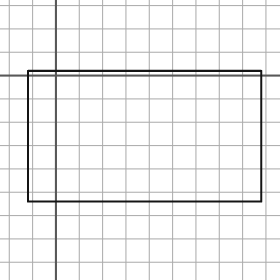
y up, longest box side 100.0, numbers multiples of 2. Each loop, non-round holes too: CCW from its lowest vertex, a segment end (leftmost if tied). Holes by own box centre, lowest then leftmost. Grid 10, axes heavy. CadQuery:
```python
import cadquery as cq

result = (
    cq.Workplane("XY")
    .moveTo(-12.0, -54.0)
    .lineTo(88.0, -54.0)
    .lineTo(88.0, 2.0)
    .lineTo(-12.0, 2.0)
    .close()
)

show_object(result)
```